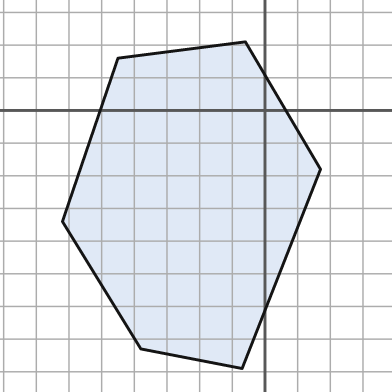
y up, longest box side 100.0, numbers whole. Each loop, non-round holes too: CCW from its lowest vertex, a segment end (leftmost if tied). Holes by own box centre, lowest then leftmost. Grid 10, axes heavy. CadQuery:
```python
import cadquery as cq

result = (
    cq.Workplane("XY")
    .moveTo(-7.0, -79.0)
    .lineTo(17.0, -18.0)
    .lineTo(-6.0, 21.0)
    .lineTo(-45.0, 16.0)
    .lineTo(-62.0, -34.0)
    .lineTo(-38.0, -73.0)
    .close()
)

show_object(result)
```